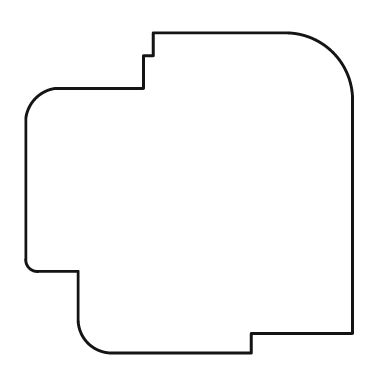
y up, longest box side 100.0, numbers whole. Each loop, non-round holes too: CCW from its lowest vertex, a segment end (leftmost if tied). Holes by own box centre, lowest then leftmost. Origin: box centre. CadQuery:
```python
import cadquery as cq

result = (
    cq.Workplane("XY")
    .moveTo(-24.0, -49.0)
    .lineTo(19.0, -49.0)
    .lineTo(19.0, -43.0)
    .lineTo(50.0, -43.0)
    .lineTo(50.0, 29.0)
    .threePointArc((44.0, 43.0), (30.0, 49.0))
    .lineTo(-11.0, 49.0)
    .lineTo(-11.0, 42.0)
    .lineTo(-14.0, 42.0)
    .lineTo(-14.0, 32.0)
    .lineTo(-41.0, 32.0)
    .threePointArc((-47.0, 29.0), (-50.0, 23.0))
    .lineTo(-50.0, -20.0)
    .threePointArc((-49.0, -23.0), (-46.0, -24.0))
    .lineTo(-34.0, -24.0)
    .lineTo(-34.0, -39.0)
    .threePointArc((-31.0, -46.0), (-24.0, -49.0))
    .close()
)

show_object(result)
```